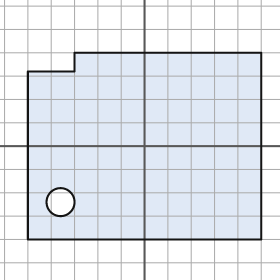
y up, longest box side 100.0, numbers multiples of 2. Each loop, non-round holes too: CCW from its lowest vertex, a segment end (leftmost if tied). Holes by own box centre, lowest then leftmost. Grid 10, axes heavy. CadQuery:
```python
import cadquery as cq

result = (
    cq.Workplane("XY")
    .moveTo(-50.0, -40.0)
    .lineTo(50.0, -40.0)
    .lineTo(50.0, 40.0)
    .lineTo(-30.0, 40.0)
    .lineTo(-30.0, 32.0)
    .lineTo(-50.0, 32.0)
    .close()
    .moveTo(-36.0, -24.0)
    .circle(6.0)
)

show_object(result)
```